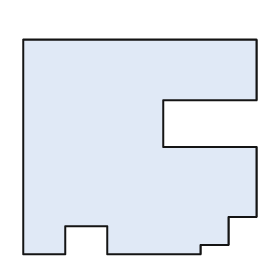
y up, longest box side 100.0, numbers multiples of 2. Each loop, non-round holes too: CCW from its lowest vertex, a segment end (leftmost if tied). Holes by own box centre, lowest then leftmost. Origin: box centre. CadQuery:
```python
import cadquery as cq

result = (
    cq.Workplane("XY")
    .moveTo(-50.0, -46.0)
    .lineTo(-32.0, -46.0)
    .lineTo(-32.0, -34.0)
    .lineTo(-14.0, -34.0)
    .lineTo(-14.0, -46.0)
    .lineTo(26.0, -46.0)
    .lineTo(26.0, -42.0)
    .lineTo(38.0, -42.0)
    .lineTo(38.0, -30.0)
    .lineTo(50.0, -30.0)
    .lineTo(50.0, 0.0)
    .lineTo(10.0, 0.0)
    .lineTo(10.0, 20.0)
    .lineTo(50.0, 20.0)
    .lineTo(50.0, 46.0)
    .lineTo(-50.0, 46.0)
    .close()
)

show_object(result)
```